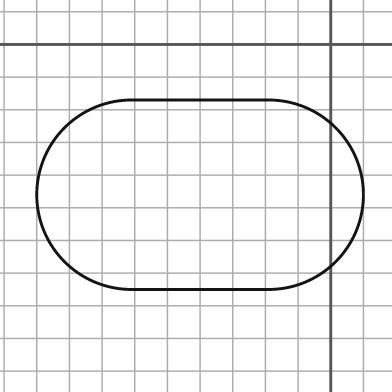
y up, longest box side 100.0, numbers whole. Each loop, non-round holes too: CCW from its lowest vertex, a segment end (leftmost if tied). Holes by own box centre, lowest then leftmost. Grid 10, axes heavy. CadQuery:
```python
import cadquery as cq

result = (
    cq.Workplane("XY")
    .moveTo(-61.0, -75.0)
    .lineTo(-19.0, -75.0)
    .threePointArc((10.0, -46.0), (-19.0, -17.0))
    .lineTo(-61.0, -17.0)
    .threePointArc((-90.0, -46.0), (-61.0, -75.0))
    .close()
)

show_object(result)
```